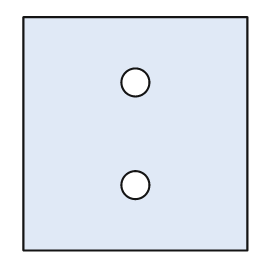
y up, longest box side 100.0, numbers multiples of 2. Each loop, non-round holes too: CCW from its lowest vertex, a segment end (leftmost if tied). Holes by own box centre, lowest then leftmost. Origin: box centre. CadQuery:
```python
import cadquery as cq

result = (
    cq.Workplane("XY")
    .moveTo(-48.0, -50.0)
    .lineTo(48.0, -50.0)
    .lineTo(48.0, 50.0)
    .lineTo(-48.0, 50.0)
    .close()
    .moveTo(0.0, -22.0)
    .circle(6.0)
    .moveTo(0.0, 22.0)
    .circle(6.0)
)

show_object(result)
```